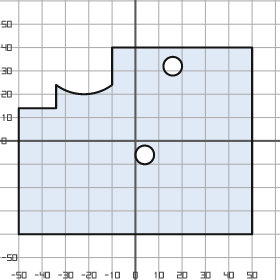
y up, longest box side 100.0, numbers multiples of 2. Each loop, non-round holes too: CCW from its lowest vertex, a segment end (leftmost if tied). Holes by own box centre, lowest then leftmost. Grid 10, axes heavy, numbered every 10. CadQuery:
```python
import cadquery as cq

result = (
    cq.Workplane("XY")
    .moveTo(-50.0, -40.0)
    .lineTo(50.0, -40.0)
    .lineTo(50.0, 40.0)
    .lineTo(-10.0, 40.0)
    .lineTo(-10.0, 24.0)
    .threePointArc((-22.0, 20.0), (-34.0, 24.0))
    .lineTo(-34.0, 14.0)
    .lineTo(-50.0, 14.0)
    .close()
    .moveTo(4.0, -6.0)
    .circle(4.0)
    .moveTo(16.0, 32.0)
    .circle(4.0)
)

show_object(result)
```